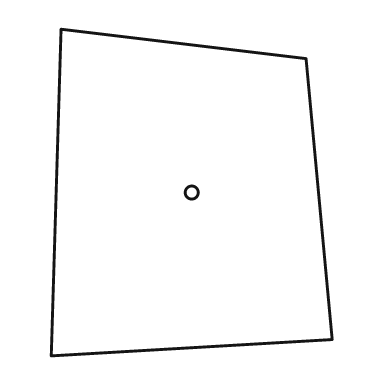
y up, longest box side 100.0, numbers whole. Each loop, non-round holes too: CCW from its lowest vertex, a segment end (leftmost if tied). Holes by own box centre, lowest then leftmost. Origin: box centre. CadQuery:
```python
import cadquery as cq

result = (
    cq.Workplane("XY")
    .moveTo(-43.0, -50.0)
    .lineTo(43.0, -45.0)
    .lineTo(35.0, 41.0)
    .lineTo(-40.0, 50.0)
    .close()
    .moveTo(0.0, 0.0)
    .circle(2.0)
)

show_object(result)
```